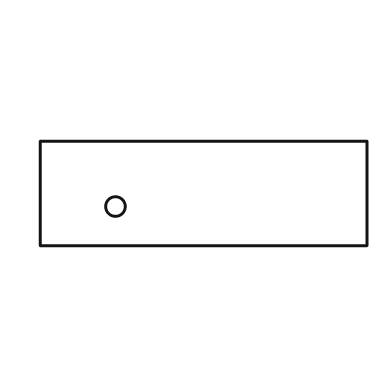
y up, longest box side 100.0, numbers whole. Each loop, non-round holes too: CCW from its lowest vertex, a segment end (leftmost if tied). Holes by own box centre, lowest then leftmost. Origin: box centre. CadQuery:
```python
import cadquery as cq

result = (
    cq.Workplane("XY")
    .moveTo(-50.0, -16.0)
    .lineTo(50.0, -16.0)
    .lineTo(50.0, 16.0)
    .lineTo(-50.0, 16.0)
    .close()
    .moveTo(-27.0, -4.0)
    .circle(3.0)
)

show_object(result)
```